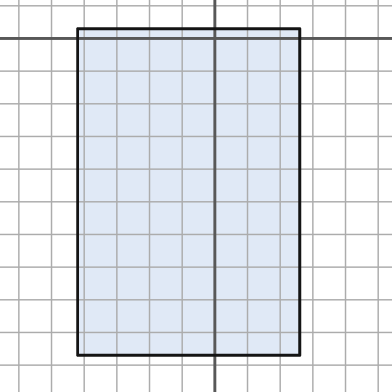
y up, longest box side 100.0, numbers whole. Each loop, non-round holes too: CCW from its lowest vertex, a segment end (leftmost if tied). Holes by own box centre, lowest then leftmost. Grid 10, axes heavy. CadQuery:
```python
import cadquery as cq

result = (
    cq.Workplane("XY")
    .moveTo(-42.0, -97.0)
    .lineTo(26.0, -97.0)
    .lineTo(26.0, 3.0)
    .lineTo(-42.0, 3.0)
    .close()
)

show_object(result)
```